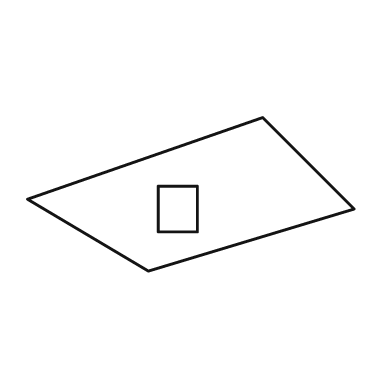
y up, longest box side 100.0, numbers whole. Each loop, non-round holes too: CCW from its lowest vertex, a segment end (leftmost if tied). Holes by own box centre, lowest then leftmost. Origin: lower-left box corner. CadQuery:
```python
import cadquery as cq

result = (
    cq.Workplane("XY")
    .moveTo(37.0, 0.0)
    .lineTo(100.0, 19.0)
    .lineTo(72.0, 47.0)
    .lineTo(0.0, 22.0)
    .close()
    .moveTo(40.0, 12.0)
    .lineTo(52.0, 12.0)
    .lineTo(52.0, 26.0)
    .lineTo(40.0, 26.0)
    .close()
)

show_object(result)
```